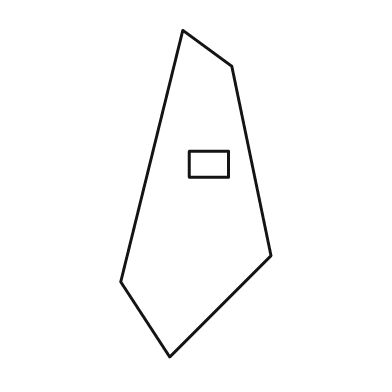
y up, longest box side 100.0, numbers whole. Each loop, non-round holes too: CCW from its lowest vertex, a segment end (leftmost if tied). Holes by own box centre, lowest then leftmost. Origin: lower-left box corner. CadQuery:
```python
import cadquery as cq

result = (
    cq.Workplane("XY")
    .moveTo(15.0, 0.0)
    .lineTo(46.0, 31.0)
    .lineTo(34.0, 89.0)
    .lineTo(19.0, 100.0)
    .lineTo(0.0, 23.0)
    .close()
    .moveTo(21.0, 55.0)
    .lineTo(33.0, 55.0)
    .lineTo(33.0, 63.0)
    .lineTo(21.0, 63.0)
    .close()
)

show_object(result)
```